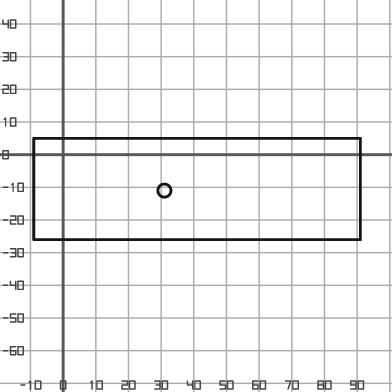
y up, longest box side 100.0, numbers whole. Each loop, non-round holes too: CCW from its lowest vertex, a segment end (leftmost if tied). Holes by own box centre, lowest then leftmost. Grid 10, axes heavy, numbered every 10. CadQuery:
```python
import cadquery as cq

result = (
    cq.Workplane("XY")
    .moveTo(-9.0, -26.0)
    .lineTo(91.0, -26.0)
    .lineTo(91.0, 5.0)
    .lineTo(-9.0, 5.0)
    .close()
    .moveTo(31.0, -11.0)
    .circle(2.0)
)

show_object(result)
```